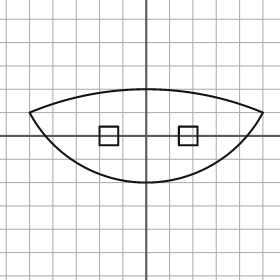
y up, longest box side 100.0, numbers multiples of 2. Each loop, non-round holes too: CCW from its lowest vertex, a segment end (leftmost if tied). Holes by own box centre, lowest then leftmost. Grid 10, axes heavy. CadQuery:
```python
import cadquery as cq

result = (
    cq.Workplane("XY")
    .moveTo(-50.0, 10.0)
    .threePointArc((0.0, -20.0), (50.0, 10.0))
    .threePointArc((0.0, 20.0), (-50.0, 10.0))
    .close()
    .moveTo(-20.0, -4.0)
    .lineTo(-12.0, -4.0)
    .lineTo(-12.0, 4.0)
    .lineTo(-20.0, 4.0)
    .close()
    .moveTo(14.0, -4.0)
    .lineTo(22.0, -4.0)
    .lineTo(22.0, 4.0)
    .lineTo(14.0, 4.0)
    .close()
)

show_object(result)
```